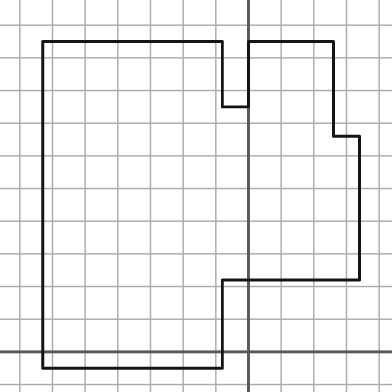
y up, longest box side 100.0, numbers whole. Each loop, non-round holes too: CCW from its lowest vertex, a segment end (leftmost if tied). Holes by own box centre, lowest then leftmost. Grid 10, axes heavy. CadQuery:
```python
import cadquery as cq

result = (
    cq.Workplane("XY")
    .moveTo(-63.0, -5.0)
    .lineTo(-8.0, -5.0)
    .lineTo(-8.0, 22.0)
    .lineTo(34.0, 22.0)
    .lineTo(34.0, 66.0)
    .lineTo(26.0, 66.0)
    .lineTo(26.0, 95.0)
    .lineTo(0.0, 95.0)
    .lineTo(0.0, 75.0)
    .lineTo(-8.0, 75.0)
    .lineTo(-8.0, 95.0)
    .lineTo(-63.0, 95.0)
    .close()
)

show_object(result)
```